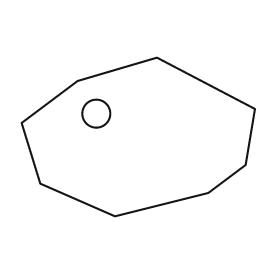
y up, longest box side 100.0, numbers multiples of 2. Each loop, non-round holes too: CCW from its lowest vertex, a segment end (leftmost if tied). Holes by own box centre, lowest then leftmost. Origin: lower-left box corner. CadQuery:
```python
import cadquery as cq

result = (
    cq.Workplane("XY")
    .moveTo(40.0, 0.0)
    .lineTo(80.0, 10.0)
    .lineTo(96.0, 22.0)
    .lineTo(100.0, 46.0)
    .lineTo(58.0, 68.0)
    .lineTo(24.0, 58.0)
    .lineTo(0.0, 40.0)
    .lineTo(8.0, 14.0)
    .close()
    .moveTo(32.0, 44.0)
    .circle(6.0)
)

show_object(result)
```